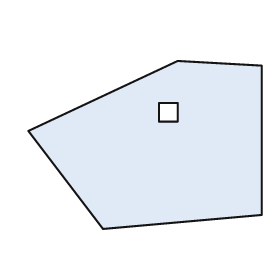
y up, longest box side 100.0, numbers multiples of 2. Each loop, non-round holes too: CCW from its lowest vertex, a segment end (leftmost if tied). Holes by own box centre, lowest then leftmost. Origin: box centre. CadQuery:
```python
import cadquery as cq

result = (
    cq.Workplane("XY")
    .moveTo(-18.0, -36.0)
    .lineTo(50.0, -30.0)
    .lineTo(50.0, 34.0)
    .lineTo(14.0, 36.0)
    .lineTo(-50.0, 6.0)
    .close()
    .moveTo(6.0, 10.0)
    .lineTo(14.0, 10.0)
    .lineTo(14.0, 18.0)
    .lineTo(6.0, 18.0)
    .close()
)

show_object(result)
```